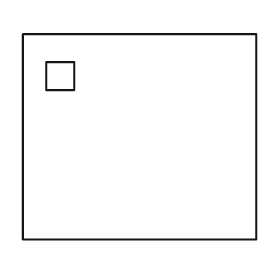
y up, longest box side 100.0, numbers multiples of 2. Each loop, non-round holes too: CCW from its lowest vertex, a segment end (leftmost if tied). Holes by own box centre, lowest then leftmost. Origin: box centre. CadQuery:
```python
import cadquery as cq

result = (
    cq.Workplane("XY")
    .moveTo(-50.0, -44.0)
    .lineTo(50.0, -44.0)
    .lineTo(50.0, 44.0)
    .lineTo(-50.0, 44.0)
    .close()
    .moveTo(-40.0, 20.0)
    .lineTo(-28.0, 20.0)
    .lineTo(-28.0, 32.0)
    .lineTo(-40.0, 32.0)
    .close()
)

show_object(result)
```